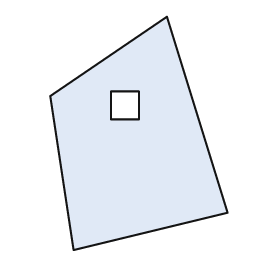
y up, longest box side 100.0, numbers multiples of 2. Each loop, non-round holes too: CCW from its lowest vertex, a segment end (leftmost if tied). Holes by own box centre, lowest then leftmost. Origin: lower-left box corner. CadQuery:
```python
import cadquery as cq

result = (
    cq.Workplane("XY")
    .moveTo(10.0, 0.0)
    .lineTo(76.0, 16.0)
    .lineTo(50.0, 100.0)
    .lineTo(0.0, 66.0)
    .close()
    .moveTo(26.0, 56.0)
    .lineTo(38.0, 56.0)
    .lineTo(38.0, 68.0)
    .lineTo(26.0, 68.0)
    .close()
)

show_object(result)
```